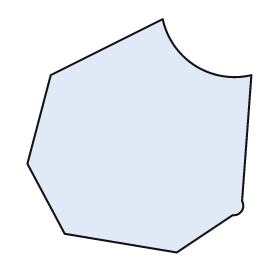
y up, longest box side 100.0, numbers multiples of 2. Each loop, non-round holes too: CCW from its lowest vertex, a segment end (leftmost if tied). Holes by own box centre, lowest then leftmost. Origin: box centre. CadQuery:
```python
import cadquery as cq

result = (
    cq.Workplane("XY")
    .moveTo(16.0, -50.0)
    .lineTo(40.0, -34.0)
    .threePointArc((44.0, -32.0), (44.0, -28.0))
    .lineTo(48.0, 26.0)
    .threePointArc((24.0, 30.0), (10.0, 50.0))
    .lineTo(-38.0, 26.0)
    .lineTo(-48.0, -12.0)
    .lineTo(-32.0, -42.0)
    .close()
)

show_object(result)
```